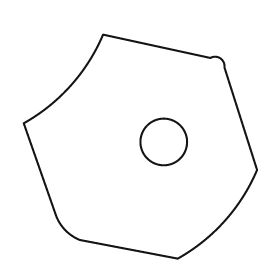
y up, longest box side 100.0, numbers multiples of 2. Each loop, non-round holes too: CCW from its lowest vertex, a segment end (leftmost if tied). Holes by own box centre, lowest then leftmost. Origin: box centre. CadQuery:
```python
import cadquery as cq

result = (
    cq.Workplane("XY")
    .moveTo(16.0, -48.0)
    .threePointArc((36.0, -32.0), (50.0, -10.0))
    .lineTo(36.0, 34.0)
    .threePointArc((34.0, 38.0), (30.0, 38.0))
    .lineTo(-16.0, 48.0)
    .threePointArc((-30.0, 26.0), (-50.0, 10.0))
    .lineTo(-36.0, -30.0)
    .threePointArc((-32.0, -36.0), (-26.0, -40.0))
    .close()
    .moveTo(10.0, 2.0)
    .circle(10.0)
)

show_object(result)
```